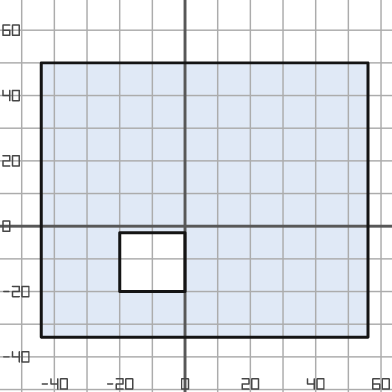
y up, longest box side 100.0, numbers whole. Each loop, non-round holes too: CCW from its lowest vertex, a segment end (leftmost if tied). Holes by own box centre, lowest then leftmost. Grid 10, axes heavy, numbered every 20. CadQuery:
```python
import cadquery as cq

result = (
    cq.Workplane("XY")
    .moveTo(-44.0, -34.0)
    .lineTo(56.0, -34.0)
    .lineTo(56.0, 50.0)
    .lineTo(-44.0, 50.0)
    .close()
    .moveTo(-20.0, -20.0)
    .lineTo(0.0, -20.0)
    .lineTo(0.0, -2.0)
    .lineTo(-20.0, -2.0)
    .close()
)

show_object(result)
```